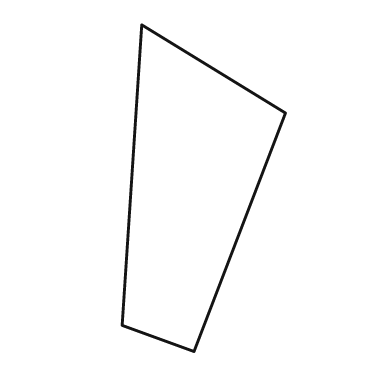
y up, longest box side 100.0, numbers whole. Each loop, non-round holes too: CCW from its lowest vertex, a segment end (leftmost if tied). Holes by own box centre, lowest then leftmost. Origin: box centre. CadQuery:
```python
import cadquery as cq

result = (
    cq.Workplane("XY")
    .moveTo(-3.0, -50.0)
    .lineTo(25.0, 23.0)
    .lineTo(-19.0, 50.0)
    .lineTo(-25.0, -42.0)
    .close()
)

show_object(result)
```